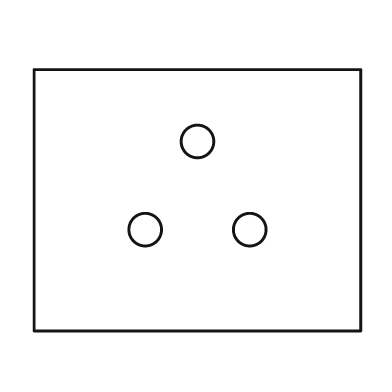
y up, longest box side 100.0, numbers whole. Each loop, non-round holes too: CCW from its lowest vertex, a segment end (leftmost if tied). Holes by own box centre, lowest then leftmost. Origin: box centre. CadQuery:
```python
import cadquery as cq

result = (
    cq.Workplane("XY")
    .moveTo(-50.0, -40.0)
    .lineTo(50.0, -40.0)
    .lineTo(50.0, 40.0)
    .lineTo(-50.0, 40.0)
    .close()
    .moveTo(-16.0, -9.0)
    .circle(5.0)
    .moveTo(16.0, -9.0)
    .circle(5.0)
    .moveTo(0.0, 18.0)
    .circle(5.0)
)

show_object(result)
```